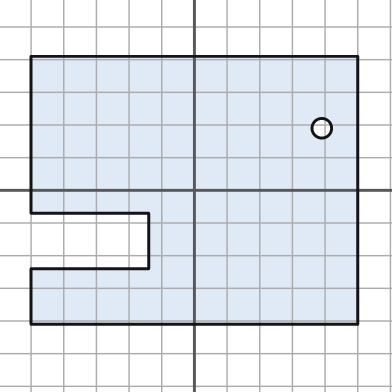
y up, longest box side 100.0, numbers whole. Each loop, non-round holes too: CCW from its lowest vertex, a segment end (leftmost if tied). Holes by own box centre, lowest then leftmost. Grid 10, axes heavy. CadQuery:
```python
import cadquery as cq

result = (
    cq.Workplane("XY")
    .moveTo(-50.0, -41.0)
    .lineTo(50.0, -41.0)
    .lineTo(50.0, 41.0)
    .lineTo(-50.0, 41.0)
    .lineTo(-50.0, -7.0)
    .lineTo(-14.0, -7.0)
    .lineTo(-14.0, -24.0)
    .lineTo(-50.0, -24.0)
    .close()
    .moveTo(39.0, 19.0)
    .circle(3.0)
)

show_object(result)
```